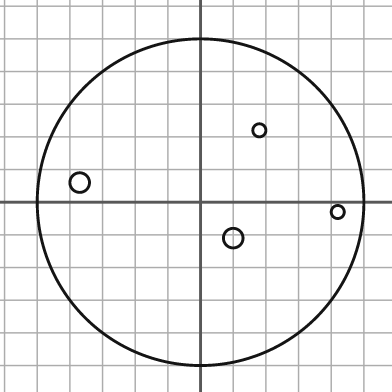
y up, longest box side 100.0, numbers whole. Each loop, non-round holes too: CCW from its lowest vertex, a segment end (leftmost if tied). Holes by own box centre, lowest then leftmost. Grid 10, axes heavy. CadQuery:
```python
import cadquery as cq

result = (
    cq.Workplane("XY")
    .moveTo(0.0, 0.0)
    .circle(50.0)
    .moveTo(10.0, -11.0)
    .circle(3.0)
    .moveTo(42.0, -3.0)
    .circle(2.0)
    .moveTo(-37.0, 6.0)
    .circle(3.0)
    .moveTo(18.0, 22.0)
    .circle(2.0)
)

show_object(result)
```